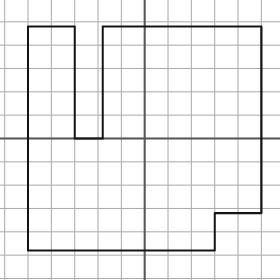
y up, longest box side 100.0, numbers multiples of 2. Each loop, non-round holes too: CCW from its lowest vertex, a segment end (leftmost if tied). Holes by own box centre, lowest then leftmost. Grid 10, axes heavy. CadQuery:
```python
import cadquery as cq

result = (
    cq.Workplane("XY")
    .moveTo(-50.0, -48.0)
    .lineTo(30.0, -48.0)
    .lineTo(30.0, -32.0)
    .lineTo(50.0, -32.0)
    .lineTo(50.0, 48.0)
    .lineTo(-18.0, 48.0)
    .lineTo(-18.0, 0.0)
    .lineTo(-30.0, 0.0)
    .lineTo(-30.0, 48.0)
    .lineTo(-50.0, 48.0)
    .close()
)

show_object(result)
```